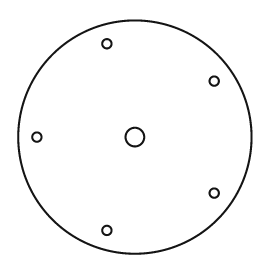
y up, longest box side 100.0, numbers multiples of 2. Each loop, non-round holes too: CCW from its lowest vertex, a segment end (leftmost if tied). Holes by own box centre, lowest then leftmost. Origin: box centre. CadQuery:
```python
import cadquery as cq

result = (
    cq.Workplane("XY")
    .moveTo(0.0, 0.0)
    .circle(50.0)
    .moveTo(-12.0, -40.0)
    .circle(2.0)
    .moveTo(34.0, -24.0)
    .circle(2.0)
    .moveTo(-42.0, 0.0)
    .circle(2.0)
    .moveTo(0.0, 0.0)
    .circle(4.0)
    .moveTo(34.0, 24.0)
    .circle(2.0)
    .moveTo(-12.0, 40.0)
    .circle(2.0)
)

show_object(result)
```